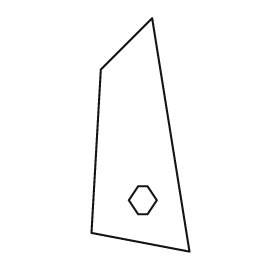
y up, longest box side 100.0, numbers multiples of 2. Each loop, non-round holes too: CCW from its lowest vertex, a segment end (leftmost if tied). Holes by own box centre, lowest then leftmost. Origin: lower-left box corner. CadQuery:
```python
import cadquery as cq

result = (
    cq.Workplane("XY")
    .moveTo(42.0, 0.0)
    .lineTo(26.0, 100.0)
    .lineTo(4.0, 78.0)
    .lineTo(0.0, 8.0)
    .close()
    .moveTo(20.0, 16.0)
    .lineTo(24.0, 16.0)
    .lineTo(28.0, 22.0)
    .lineTo(24.0, 28.0)
    .lineTo(20.0, 28.0)
    .lineTo(16.0, 22.0)
    .close()
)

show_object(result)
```